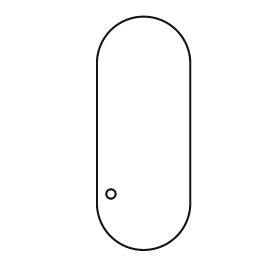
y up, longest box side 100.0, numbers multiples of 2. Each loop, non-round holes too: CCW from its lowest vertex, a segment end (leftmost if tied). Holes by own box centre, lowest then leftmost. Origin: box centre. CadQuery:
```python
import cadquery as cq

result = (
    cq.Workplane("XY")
    .moveTo(-20.0, -30.0)
    .threePointArc((0.0, -50.0), (20.0, -30.0))
    .lineTo(20.0, 30.0)
    .threePointArc((0.0, 50.0), (-20.0, 30.0))
    .close()
    .moveTo(-14.0, -26.0)
    .circle(2.0)
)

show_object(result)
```